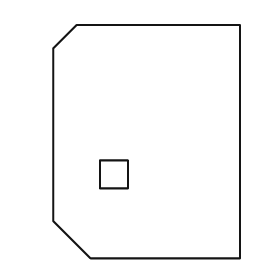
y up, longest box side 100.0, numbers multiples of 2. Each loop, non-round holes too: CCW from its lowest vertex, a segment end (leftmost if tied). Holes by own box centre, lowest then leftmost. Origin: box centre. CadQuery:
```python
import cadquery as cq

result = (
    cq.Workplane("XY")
    .moveTo(-24.0, -50.0)
    .lineTo(40.0, -50.0)
    .lineTo(40.0, 50.0)
    .lineTo(-30.0, 50.0)
    .lineTo(-40.0, 40.0)
    .lineTo(-40.0, -34.0)
    .close()
    .moveTo(-20.0, -20.0)
    .lineTo(-8.0, -20.0)
    .lineTo(-8.0, -8.0)
    .lineTo(-20.0, -8.0)
    .close()
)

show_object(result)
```